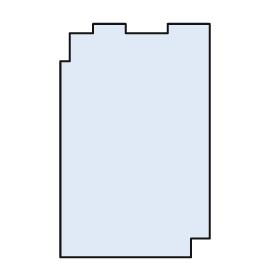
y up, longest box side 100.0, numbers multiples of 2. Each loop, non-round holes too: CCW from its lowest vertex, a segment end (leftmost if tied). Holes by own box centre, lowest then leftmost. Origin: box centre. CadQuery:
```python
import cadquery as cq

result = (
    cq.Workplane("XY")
    .moveTo(-32.0, -50.0)
    .lineTo(24.0, -50.0)
    .lineTo(24.0, -42.0)
    .lineTo(32.0, -42.0)
    .lineTo(32.0, 50.0)
    .lineTo(14.0, 50.0)
    .lineTo(14.0, 46.0)
    .lineTo(-4.0, 46.0)
    .lineTo(-4.0, 50.0)
    .lineTo(-18.0, 50.0)
    .lineTo(-18.0, 46.0)
    .lineTo(-28.0, 46.0)
    .lineTo(-28.0, 34.0)
    .lineTo(-32.0, 34.0)
    .close()
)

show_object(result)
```